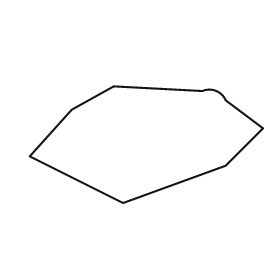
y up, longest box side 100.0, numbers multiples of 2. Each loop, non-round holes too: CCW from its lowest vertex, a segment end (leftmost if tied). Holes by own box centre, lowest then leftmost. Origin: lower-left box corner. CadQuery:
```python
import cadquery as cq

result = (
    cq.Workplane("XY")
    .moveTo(40.0, 0.0)
    .lineTo(84.0, 16.0)
    .lineTo(100.0, 32.0)
    .lineTo(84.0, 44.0)
    .threePointArc((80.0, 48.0), (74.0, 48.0))
    .lineTo(36.0, 50.0)
    .lineTo(18.0, 40.0)
    .lineTo(0.0, 20.0)
    .close()
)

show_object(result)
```